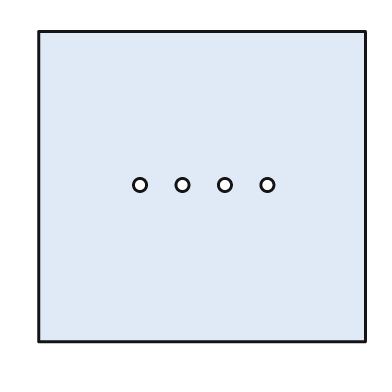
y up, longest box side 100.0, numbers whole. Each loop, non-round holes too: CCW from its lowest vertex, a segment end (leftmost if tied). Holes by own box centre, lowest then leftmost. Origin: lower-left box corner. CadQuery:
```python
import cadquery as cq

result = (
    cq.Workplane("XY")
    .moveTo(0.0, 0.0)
    .lineTo(100.0, 0.0)
    .lineTo(100.0, 95.0)
    .lineTo(0.0, 95.0)
    .close()
    .moveTo(31.0, 48.0)
    .circle(2.0)
    .moveTo(44.0, 48.0)
    .circle(2.0)
    .moveTo(57.0, 48.0)
    .circle(2.0)
    .moveTo(70.0, 48.0)
    .circle(2.0)
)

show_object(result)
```